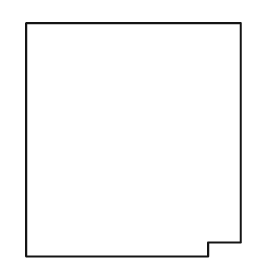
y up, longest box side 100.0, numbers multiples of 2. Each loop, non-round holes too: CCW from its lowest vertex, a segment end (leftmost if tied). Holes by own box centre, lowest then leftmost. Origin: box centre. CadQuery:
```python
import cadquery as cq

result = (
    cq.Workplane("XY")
    .moveTo(-46.0, -50.0)
    .lineTo(32.0, -50.0)
    .lineTo(32.0, -44.0)
    .lineTo(46.0, -44.0)
    .lineTo(46.0, 50.0)
    .lineTo(-46.0, 50.0)
    .close()
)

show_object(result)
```